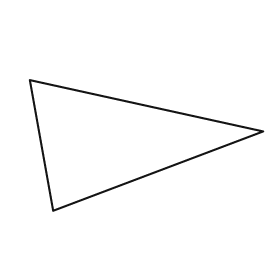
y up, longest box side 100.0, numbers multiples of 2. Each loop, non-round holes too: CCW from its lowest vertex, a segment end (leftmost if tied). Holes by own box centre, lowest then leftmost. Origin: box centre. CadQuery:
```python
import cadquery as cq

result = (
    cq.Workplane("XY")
    .moveTo(-40.0, -28.0)
    .lineTo(50.0, 6.0)
    .lineTo(-50.0, 28.0)
    .close()
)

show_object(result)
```